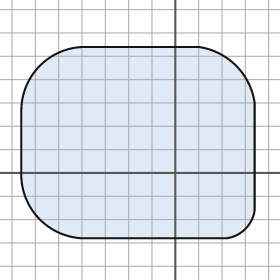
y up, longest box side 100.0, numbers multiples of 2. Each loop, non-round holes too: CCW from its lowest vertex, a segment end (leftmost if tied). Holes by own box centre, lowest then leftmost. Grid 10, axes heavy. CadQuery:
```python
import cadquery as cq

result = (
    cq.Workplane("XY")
    .moveTo(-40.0, -28.0)
    .lineTo(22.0, -28.0)
    .threePointArc((30.0, -24.0), (34.0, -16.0))
    .lineTo(34.0, 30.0)
    .threePointArc((26.0, 46.0), (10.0, 54.0))
    .lineTo(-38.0, 54.0)
    .threePointArc((-58.0, 46.0), (-66.0, 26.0))
    .lineTo(-66.0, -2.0)
    .threePointArc((-58.0, -20.0), (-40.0, -28.0))
    .close()
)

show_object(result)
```